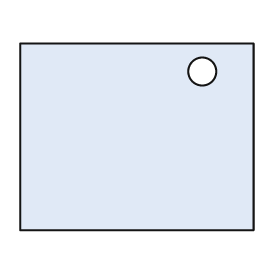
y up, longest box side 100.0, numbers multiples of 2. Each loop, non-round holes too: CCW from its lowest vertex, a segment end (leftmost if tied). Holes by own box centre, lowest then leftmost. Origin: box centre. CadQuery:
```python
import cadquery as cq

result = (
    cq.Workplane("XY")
    .moveTo(-50.0, -40.0)
    .lineTo(50.0, -40.0)
    .lineTo(50.0, 40.0)
    .lineTo(-50.0, 40.0)
    .close()
    .moveTo(28.0, 28.0)
    .circle(6.0)
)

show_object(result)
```